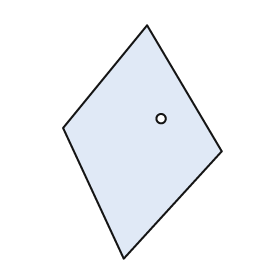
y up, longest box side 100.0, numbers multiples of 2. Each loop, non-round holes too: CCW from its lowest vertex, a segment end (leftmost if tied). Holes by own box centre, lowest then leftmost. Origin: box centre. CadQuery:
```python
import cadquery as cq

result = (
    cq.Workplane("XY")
    .moveTo(-8.0, -50.0)
    .lineTo(34.0, -4.0)
    .lineTo(2.0, 50.0)
    .lineTo(-34.0, 6.0)
    .close()
    .moveTo(8.0, 10.0)
    .circle(2.0)
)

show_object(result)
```